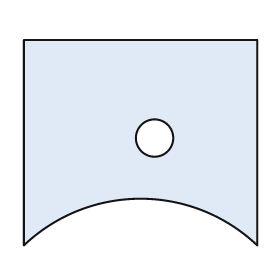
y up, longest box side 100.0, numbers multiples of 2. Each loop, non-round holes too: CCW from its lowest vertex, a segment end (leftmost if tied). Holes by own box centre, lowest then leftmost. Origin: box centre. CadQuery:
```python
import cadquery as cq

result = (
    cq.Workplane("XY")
    .moveTo(-50.0, -44.0)
    .threePointArc((0.0, -24.0), (50.0, -44.0))
    .lineTo(50.0, 44.0)
    .lineTo(-50.0, 44.0)
    .close()
    .moveTo(6.0, 2.0)
    .circle(8.0)
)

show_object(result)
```